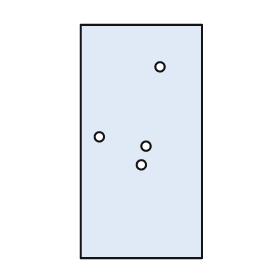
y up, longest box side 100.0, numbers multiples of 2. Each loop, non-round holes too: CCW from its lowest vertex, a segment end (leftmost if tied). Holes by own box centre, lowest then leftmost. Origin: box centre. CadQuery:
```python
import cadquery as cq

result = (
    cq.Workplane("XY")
    .moveTo(-26.0, -50.0)
    .lineTo(26.0, -50.0)
    .lineTo(26.0, 50.0)
    .lineTo(-26.0, 50.0)
    .close()
    .moveTo(0.0, -10.0)
    .circle(2.0)
    .moveTo(2.0, -2.0)
    .circle(2.0)
    .moveTo(-18.0, 2.0)
    .circle(2.0)
    .moveTo(8.0, 32.0)
    .circle(2.0)
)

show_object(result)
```